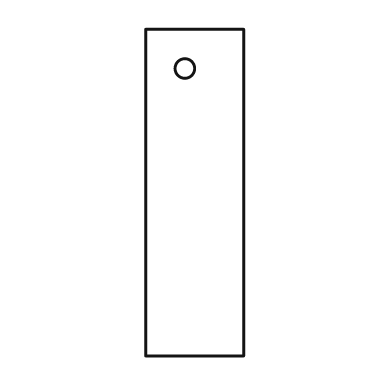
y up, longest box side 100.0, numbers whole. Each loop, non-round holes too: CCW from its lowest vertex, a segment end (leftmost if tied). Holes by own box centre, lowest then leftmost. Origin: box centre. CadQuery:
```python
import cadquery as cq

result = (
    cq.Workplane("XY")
    .moveTo(-15.0, -50.0)
    .lineTo(15.0, -50.0)
    .lineTo(15.0, 50.0)
    .lineTo(-15.0, 50.0)
    .close()
    .moveTo(-3.0, 38.0)
    .circle(3.0)
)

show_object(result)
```